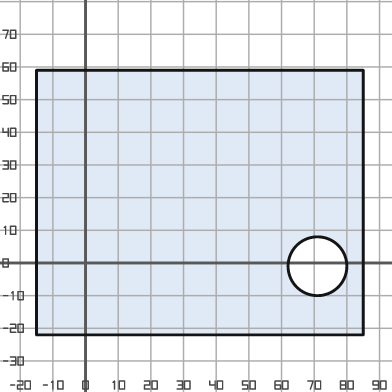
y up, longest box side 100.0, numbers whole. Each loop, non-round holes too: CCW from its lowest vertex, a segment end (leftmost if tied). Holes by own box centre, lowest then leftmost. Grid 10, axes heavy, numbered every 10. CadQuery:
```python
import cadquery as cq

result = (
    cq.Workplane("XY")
    .moveTo(-15.0, -22.0)
    .lineTo(85.0, -22.0)
    .lineTo(85.0, 59.0)
    .lineTo(-15.0, 59.0)
    .close()
    .moveTo(71.0, -1.0)
    .circle(9.0)
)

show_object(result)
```